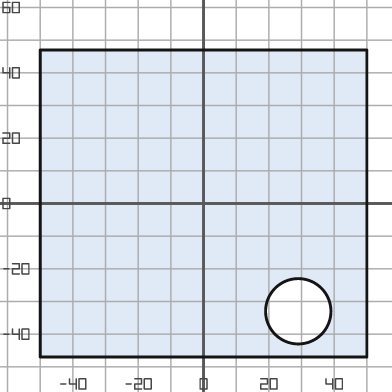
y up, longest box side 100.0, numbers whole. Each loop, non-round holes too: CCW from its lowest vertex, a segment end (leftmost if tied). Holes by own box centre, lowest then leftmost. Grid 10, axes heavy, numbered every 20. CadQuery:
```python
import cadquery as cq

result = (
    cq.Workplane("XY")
    .moveTo(-50.0, -47.0)
    .lineTo(50.0, -47.0)
    .lineTo(50.0, 47.0)
    .lineTo(-50.0, 47.0)
    .close()
    .moveTo(29.0, -33.0)
    .circle(10.0)
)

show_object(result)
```